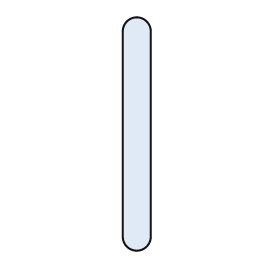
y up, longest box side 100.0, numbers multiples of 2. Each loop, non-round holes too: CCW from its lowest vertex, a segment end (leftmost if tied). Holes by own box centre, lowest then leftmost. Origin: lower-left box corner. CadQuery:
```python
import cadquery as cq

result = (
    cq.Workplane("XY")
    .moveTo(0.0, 6.0)
    .threePointArc((6.0, 0.0), (12.0, 6.0))
    .lineTo(12.0, 94.0)
    .threePointArc((6.0, 100.0), (0.0, 94.0))
    .close()
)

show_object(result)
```